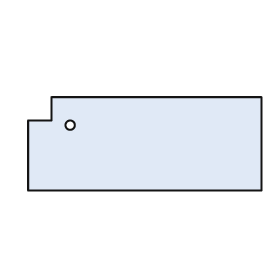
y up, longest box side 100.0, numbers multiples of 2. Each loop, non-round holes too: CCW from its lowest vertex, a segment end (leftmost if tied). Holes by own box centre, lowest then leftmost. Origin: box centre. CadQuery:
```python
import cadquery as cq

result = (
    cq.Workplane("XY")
    .moveTo(-50.0, -20.0)
    .lineTo(50.0, -20.0)
    .lineTo(50.0, 20.0)
    .lineTo(-40.0, 20.0)
    .lineTo(-40.0, 10.0)
    .lineTo(-50.0, 10.0)
    .close()
    .moveTo(-32.0, 8.0)
    .circle(2.0)
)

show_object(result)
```